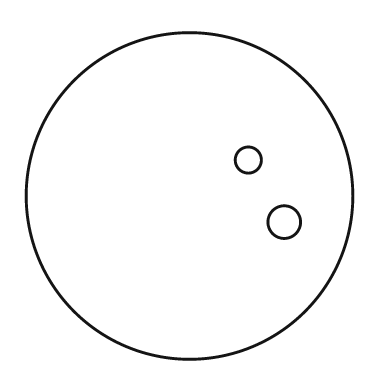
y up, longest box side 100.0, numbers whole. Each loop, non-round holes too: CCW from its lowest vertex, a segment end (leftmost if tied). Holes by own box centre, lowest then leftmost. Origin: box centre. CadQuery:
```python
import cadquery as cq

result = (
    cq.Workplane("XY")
    .moveTo(0.0, 0.0)
    .circle(50.0)
    .moveTo(29.0, -8.0)
    .circle(5.0)
    .moveTo(18.0, 11.0)
    .circle(4.0)
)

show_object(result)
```